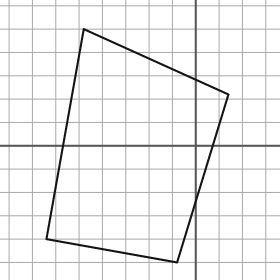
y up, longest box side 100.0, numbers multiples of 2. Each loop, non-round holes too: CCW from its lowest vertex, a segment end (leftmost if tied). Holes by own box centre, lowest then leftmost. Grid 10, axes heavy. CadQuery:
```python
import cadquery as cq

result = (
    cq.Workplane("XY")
    .moveTo(-8.0, -50.0)
    .lineTo(14.0, 22.0)
    .lineTo(-48.0, 50.0)
    .lineTo(-64.0, -40.0)
    .close()
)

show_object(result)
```